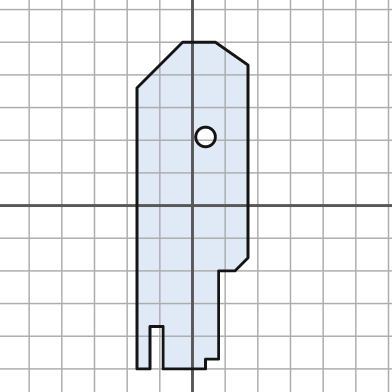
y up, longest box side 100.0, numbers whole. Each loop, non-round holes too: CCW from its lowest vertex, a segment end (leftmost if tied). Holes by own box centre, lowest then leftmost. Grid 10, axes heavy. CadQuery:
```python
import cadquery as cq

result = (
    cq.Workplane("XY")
    .moveTo(-17.0, -50.0)
    .lineTo(-13.0, -50.0)
    .lineTo(-13.0, -37.0)
    .lineTo(-9.0, -37.0)
    .lineTo(-9.0, -50.0)
    .lineTo(4.0, -50.0)
    .lineTo(4.0, -47.0)
    .lineTo(8.0, -47.0)
    .lineTo(8.0, -20.0)
    .lineTo(13.0, -20.0)
    .lineTo(17.0, -16.0)
    .lineTo(17.0, 43.0)
    .lineTo(7.0, 50.0)
    .lineTo(-3.0, 50.0)
    .lineTo(-17.0, 36.0)
    .close()
    .moveTo(4.0, 21.0)
    .circle(3.0)
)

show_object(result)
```